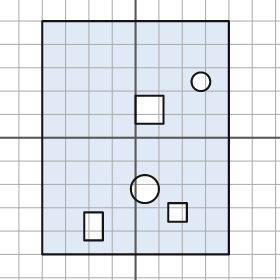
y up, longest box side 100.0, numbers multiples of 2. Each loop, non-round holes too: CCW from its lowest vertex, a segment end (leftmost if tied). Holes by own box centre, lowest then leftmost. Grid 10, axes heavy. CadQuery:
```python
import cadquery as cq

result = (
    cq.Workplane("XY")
    .moveTo(-40.0, -50.0)
    .lineTo(40.0, -50.0)
    .lineTo(40.0, 50.0)
    .lineTo(-40.0, 50.0)
    .close()
    .moveTo(-22.0, -44.0)
    .lineTo(-14.0, -44.0)
    .lineTo(-14.0, -32.0)
    .lineTo(-22.0, -32.0)
    .close()
    .moveTo(14.0, -36.0)
    .lineTo(22.0, -36.0)
    .lineTo(22.0, -28.0)
    .lineTo(14.0, -28.0)
    .close()
    .moveTo(4.0, -22.0)
    .circle(6.0)
    .moveTo(0.0, 6.0)
    .lineTo(12.0, 6.0)
    .lineTo(12.0, 18.0)
    .lineTo(0.0, 18.0)
    .close()
    .moveTo(28.0, 24.0)
    .circle(4.0)
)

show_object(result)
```